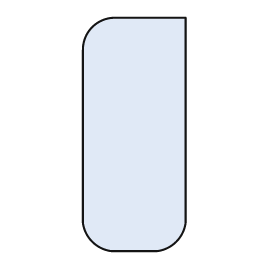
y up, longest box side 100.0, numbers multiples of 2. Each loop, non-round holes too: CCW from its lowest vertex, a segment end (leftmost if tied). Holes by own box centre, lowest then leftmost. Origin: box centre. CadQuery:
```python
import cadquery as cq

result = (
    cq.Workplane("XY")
    .moveTo(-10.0, -50.0)
    .lineTo(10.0, -50.0)
    .threePointArc((18.0, -46.0), (22.0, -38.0))
    .lineTo(22.0, 50.0)
    .lineTo(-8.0, 50.0)
    .threePointArc((-18.0, 46.0), (-22.0, 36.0))
    .lineTo(-22.0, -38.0)
    .threePointArc((-18.0, -46.0), (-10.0, -50.0))
    .close()
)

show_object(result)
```